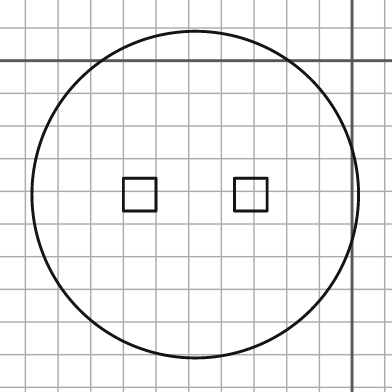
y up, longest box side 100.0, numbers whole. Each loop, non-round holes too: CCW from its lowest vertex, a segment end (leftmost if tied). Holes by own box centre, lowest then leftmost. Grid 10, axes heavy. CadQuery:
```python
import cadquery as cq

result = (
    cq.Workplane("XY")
    .moveTo(-48.0, -41.0)
    .circle(50.0)
    .moveTo(-70.0, -46.0)
    .lineTo(-60.0, -46.0)
    .lineTo(-60.0, -36.0)
    .lineTo(-70.0, -36.0)
    .close()
    .moveTo(-36.0, -46.0)
    .lineTo(-26.0, -46.0)
    .lineTo(-26.0, -36.0)
    .lineTo(-36.0, -36.0)
    .close()
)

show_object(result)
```